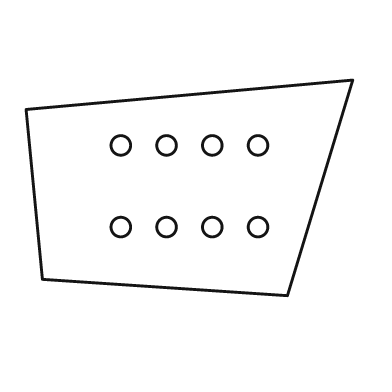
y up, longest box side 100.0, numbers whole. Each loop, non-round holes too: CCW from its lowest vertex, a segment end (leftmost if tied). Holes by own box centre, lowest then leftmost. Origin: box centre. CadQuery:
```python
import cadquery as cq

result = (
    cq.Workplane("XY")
    .moveTo(30.0, -33.0)
    .lineTo(50.0, 33.0)
    .lineTo(-50.0, 24.0)
    .lineTo(-45.0, -28.0)
    .close()
    .moveTo(-21.0, -12.0)
    .circle(3.0)
    .moveTo(-7.0, -12.0)
    .circle(3.0)
    .moveTo(7.0, -12.0)
    .circle(3.0)
    .moveTo(21.0, -12.0)
    .circle(3.0)
    .moveTo(-21.0, 13.0)
    .circle(3.0)
    .moveTo(-7.0, 13.0)
    .circle(3.0)
    .moveTo(7.0, 13.0)
    .circle(3.0)
    .moveTo(21.0, 13.0)
    .circle(3.0)
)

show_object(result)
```